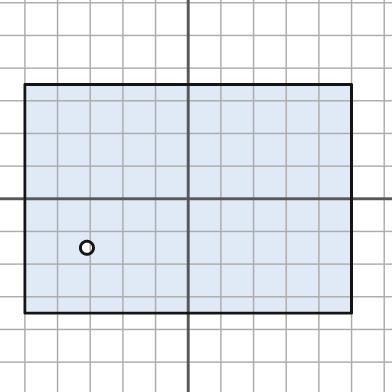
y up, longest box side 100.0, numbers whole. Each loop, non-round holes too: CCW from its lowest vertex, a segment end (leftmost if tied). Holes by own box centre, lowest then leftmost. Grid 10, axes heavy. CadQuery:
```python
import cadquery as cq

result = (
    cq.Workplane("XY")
    .moveTo(-50.0, -35.0)
    .lineTo(50.0, -35.0)
    .lineTo(50.0, 35.0)
    .lineTo(-50.0, 35.0)
    .close()
    .moveTo(-31.0, -15.0)
    .circle(2.0)
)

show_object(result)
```